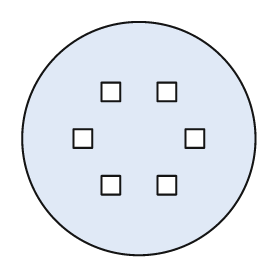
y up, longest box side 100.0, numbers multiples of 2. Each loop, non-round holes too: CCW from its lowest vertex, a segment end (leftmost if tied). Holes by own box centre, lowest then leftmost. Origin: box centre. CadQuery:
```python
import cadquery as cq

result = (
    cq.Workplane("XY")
    .moveTo(0.0, 0.0)
    .circle(50.0)
    .moveTo(-16.0, -24.0)
    .lineTo(-8.0, -24.0)
    .lineTo(-8.0, -16.0)
    .lineTo(-16.0, -16.0)
    .close()
    .moveTo(8.0, -24.0)
    .lineTo(16.0, -24.0)
    .lineTo(16.0, -16.0)
    .lineTo(8.0, -16.0)
    .close()
    .moveTo(-28.0, -4.0)
    .lineTo(-20.0, -4.0)
    .lineTo(-20.0, 4.0)
    .lineTo(-28.0, 4.0)
    .close()
    .moveTo(20.0, -4.0)
    .lineTo(28.0, -4.0)
    .lineTo(28.0, 4.0)
    .lineTo(20.0, 4.0)
    .close()
    .moveTo(-16.0, 16.0)
    .lineTo(-8.0, 16.0)
    .lineTo(-8.0, 24.0)
    .lineTo(-16.0, 24.0)
    .close()
    .moveTo(8.0, 16.0)
    .lineTo(16.0, 16.0)
    .lineTo(16.0, 24.0)
    .lineTo(8.0, 24.0)
    .close()
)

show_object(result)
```